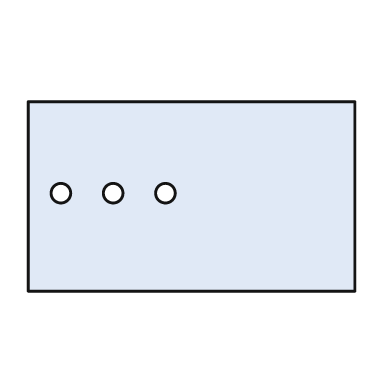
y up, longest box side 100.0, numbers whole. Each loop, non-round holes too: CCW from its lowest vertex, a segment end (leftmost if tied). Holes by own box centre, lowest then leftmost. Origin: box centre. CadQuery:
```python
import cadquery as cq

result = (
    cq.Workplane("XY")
    .moveTo(-50.0, -29.0)
    .lineTo(50.0, -29.0)
    .lineTo(50.0, 29.0)
    .lineTo(-50.0, 29.0)
    .close()
    .moveTo(-40.0, 1.0)
    .circle(3.0)
    .moveTo(-24.0, 1.0)
    .circle(3.0)
    .moveTo(-8.0, 1.0)
    .circle(3.0)
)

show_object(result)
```